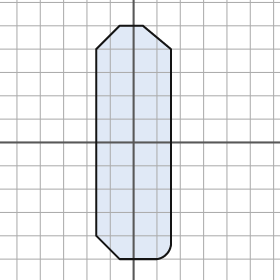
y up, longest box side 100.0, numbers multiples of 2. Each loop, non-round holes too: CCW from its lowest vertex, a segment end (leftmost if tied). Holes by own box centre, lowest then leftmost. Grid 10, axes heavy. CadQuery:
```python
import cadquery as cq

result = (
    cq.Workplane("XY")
    .moveTo(-6.0, -50.0)
    .lineTo(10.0, -50.0)
    .threePointArc((14.0, -48.0), (16.0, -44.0))
    .lineTo(16.0, 40.0)
    .lineTo(4.0, 50.0)
    .lineTo(-6.0, 50.0)
    .lineTo(-16.0, 40.0)
    .lineTo(-16.0, -40.0)
    .close()
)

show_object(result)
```